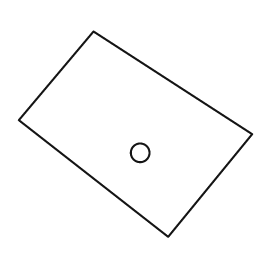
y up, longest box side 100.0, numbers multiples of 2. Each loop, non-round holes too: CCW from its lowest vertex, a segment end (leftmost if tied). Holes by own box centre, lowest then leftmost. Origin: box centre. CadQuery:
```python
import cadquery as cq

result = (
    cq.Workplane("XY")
    .moveTo(14.0, -44.0)
    .lineTo(50.0, 0.0)
    .lineTo(-18.0, 44.0)
    .lineTo(-50.0, 6.0)
    .close()
    .moveTo(2.0, -8.0)
    .circle(4.0)
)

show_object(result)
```